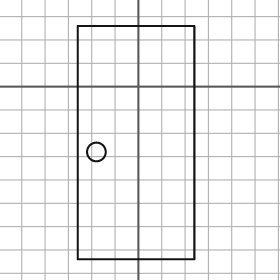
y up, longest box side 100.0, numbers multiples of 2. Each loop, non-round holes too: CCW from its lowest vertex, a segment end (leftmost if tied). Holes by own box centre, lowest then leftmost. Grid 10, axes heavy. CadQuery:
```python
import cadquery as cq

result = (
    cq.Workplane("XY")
    .moveTo(-26.0, -74.0)
    .lineTo(24.0, -74.0)
    .lineTo(24.0, 26.0)
    .lineTo(-26.0, 26.0)
    .close()
    .moveTo(-18.0, -28.0)
    .circle(4.0)
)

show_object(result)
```